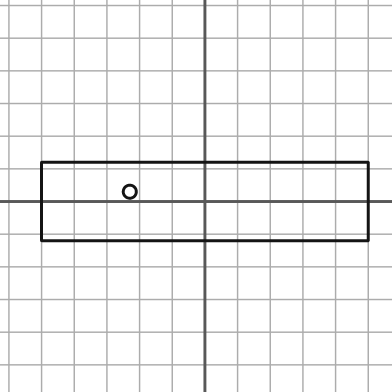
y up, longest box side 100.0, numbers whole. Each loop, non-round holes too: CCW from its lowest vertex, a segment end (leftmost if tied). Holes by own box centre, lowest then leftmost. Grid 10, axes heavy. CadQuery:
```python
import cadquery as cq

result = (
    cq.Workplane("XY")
    .moveTo(-50.0, -12.0)
    .lineTo(50.0, -12.0)
    .lineTo(50.0, 12.0)
    .lineTo(-50.0, 12.0)
    .close()
    .moveTo(-23.0, 3.0)
    .circle(2.0)
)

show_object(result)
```